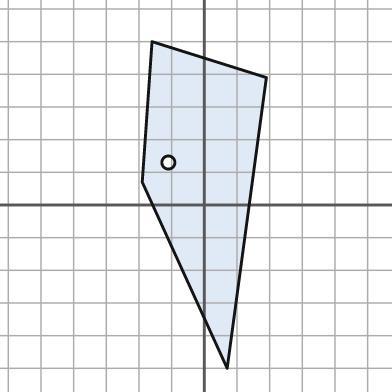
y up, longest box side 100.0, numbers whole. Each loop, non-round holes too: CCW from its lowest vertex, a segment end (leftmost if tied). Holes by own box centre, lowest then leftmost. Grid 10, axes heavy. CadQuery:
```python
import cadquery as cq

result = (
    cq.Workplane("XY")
    .moveTo(7.0, -50.0)
    .lineTo(19.0, 39.0)
    .lineTo(-16.0, 50.0)
    .lineTo(-19.0, 7.0)
    .close()
    .moveTo(-11.0, 13.0)
    .circle(2.0)
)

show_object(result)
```